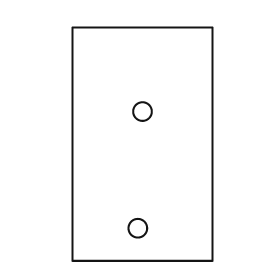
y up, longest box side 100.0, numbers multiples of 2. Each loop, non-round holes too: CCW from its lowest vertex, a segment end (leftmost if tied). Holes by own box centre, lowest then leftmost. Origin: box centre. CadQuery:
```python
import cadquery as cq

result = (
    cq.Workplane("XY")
    .moveTo(-30.0, -50.0)
    .lineTo(30.0, -50.0)
    .lineTo(30.0, 50.0)
    .lineTo(-30.0, 50.0)
    .close()
    .moveTo(-2.0, -36.0)
    .circle(4.0)
    .moveTo(0.0, 14.0)
    .circle(4.0)
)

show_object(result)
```